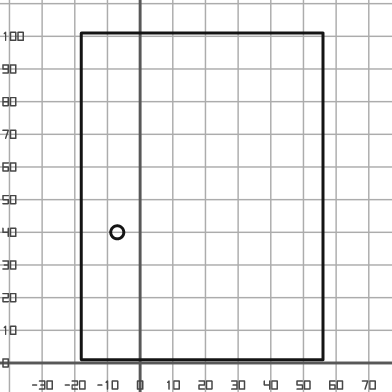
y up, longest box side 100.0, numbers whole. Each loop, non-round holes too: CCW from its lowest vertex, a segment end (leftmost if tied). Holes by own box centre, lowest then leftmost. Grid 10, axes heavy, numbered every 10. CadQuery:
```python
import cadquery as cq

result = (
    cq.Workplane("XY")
    .moveTo(-18.0, 1.0)
    .lineTo(56.0, 1.0)
    .lineTo(56.0, 101.0)
    .lineTo(-18.0, 101.0)
    .close()
    .moveTo(-7.0, 40.0)
    .circle(2.0)
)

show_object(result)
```